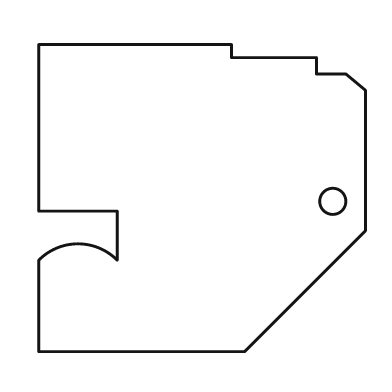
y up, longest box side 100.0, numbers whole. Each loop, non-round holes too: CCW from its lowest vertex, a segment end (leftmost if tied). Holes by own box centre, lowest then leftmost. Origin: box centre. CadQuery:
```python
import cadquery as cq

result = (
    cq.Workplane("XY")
    .moveTo(-50.0, -47.0)
    .lineTo(13.0, -47.0)
    .lineTo(50.0, -10.0)
    .lineTo(50.0, 33.0)
    .lineTo(44.0, 38.0)
    .lineTo(35.0, 38.0)
    .lineTo(35.0, 43.0)
    .lineTo(9.0, 43.0)
    .lineTo(9.0, 47.0)
    .lineTo(-50.0, 47.0)
    .lineTo(-50.0, -4.0)
    .lineTo(-26.0, -4.0)
    .lineTo(-26.0, -19.0)
    .threePointArc((-38.0, -14.0), (-50.0, -19.0))
    .close()
    .moveTo(40.0, -1.0)
    .circle(4.0)
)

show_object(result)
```